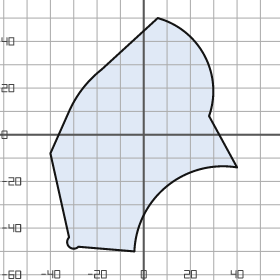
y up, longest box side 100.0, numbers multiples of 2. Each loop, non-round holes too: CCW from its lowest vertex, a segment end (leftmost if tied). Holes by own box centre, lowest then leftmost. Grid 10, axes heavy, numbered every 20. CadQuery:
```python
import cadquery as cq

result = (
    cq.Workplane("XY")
    .moveTo(-4.0, -50.0)
    .threePointArc((10.0, -22.0), (40.0, -14.0))
    .lineTo(28.0, 8.0)
    .threePointArc((26.0, 34.0), (6.0, 50.0))
    .lineTo(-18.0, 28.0)
    .threePointArc((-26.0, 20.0), (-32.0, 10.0))
    .lineTo(-40.0, -8.0)
    .lineTo(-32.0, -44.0)
    .threePointArc((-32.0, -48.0), (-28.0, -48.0))
    .close()
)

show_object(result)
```